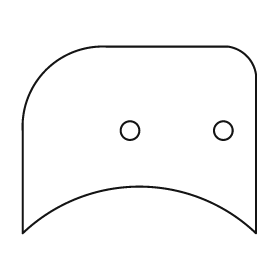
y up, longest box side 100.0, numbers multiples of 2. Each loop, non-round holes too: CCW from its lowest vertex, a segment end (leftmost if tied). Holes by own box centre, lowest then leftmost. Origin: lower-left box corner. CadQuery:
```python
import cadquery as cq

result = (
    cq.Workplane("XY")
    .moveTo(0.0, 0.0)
    .threePointArc((50.0, 20.0), (100.0, 0.0))
    .lineTo(100.0, 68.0)
    .threePointArc((96.0, 76.0), (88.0, 80.0))
    .lineTo(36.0, 80.0)
    .threePointArc((10.0, 70.0), (0.0, 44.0))
    .close()
    .moveTo(46.0, 44.0)
    .circle(4.0)
    .moveTo(86.0, 44.0)
    .circle(4.0)
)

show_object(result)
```